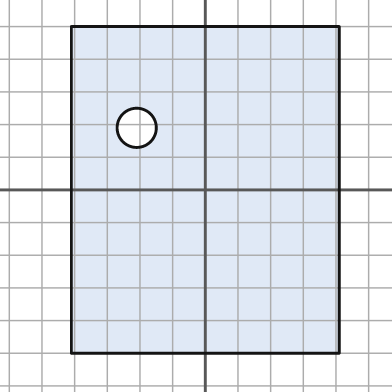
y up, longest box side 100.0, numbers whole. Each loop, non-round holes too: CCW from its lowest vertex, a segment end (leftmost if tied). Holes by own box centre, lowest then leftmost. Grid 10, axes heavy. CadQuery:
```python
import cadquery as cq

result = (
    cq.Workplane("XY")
    .moveTo(-41.0, -50.0)
    .lineTo(41.0, -50.0)
    .lineTo(41.0, 50.0)
    .lineTo(-41.0, 50.0)
    .close()
    .moveTo(-21.0, 19.0)
    .circle(6.0)
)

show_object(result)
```